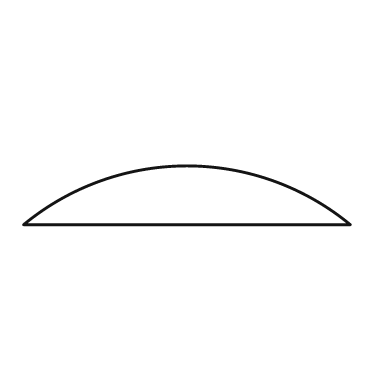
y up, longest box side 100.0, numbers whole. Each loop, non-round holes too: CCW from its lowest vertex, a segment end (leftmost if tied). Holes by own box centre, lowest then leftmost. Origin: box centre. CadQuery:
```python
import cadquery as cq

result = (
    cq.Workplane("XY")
    .moveTo(-50.0, -9.0)
    .lineTo(50.0, -9.0)
    .threePointArc((0.0, 9.0), (-50.0, -9.0))
    .close()
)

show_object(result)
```